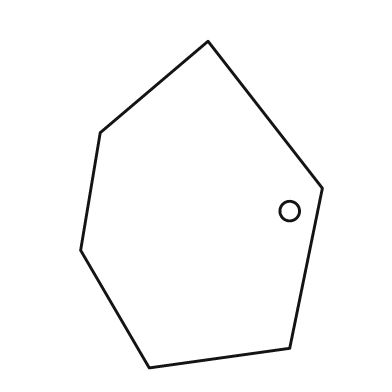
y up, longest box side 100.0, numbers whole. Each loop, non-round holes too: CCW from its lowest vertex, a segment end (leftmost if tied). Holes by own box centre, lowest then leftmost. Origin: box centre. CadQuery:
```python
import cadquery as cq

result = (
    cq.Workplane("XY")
    .moveTo(-16.0, -50.0)
    .lineTo(27.0, -44.0)
    .lineTo(37.0, 5.0)
    .lineTo(2.0, 50.0)
    .lineTo(-31.0, 22.0)
    .lineTo(-37.0, -14.0)
    .close()
    .moveTo(27.0, -2.0)
    .circle(3.0)
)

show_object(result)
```